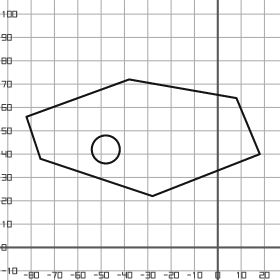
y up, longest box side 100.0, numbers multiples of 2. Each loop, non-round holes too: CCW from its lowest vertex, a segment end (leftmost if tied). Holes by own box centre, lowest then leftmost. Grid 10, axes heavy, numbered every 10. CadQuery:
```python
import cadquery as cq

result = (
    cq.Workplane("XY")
    .moveTo(-28.0, 22.0)
    .lineTo(18.0, 40.0)
    .lineTo(8.0, 64.0)
    .lineTo(-38.0, 72.0)
    .lineTo(-82.0, 56.0)
    .lineTo(-76.0, 38.0)
    .close()
    .moveTo(-48.0, 42.0)
    .circle(6.0)
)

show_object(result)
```